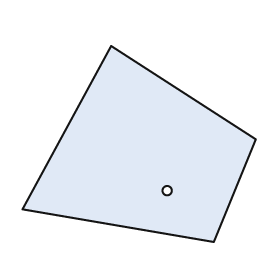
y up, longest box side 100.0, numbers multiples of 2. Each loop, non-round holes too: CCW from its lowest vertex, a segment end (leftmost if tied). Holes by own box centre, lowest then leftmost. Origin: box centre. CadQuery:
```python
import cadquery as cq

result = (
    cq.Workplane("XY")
    .moveTo(32.0, -42.0)
    .lineTo(50.0, 2.0)
    .lineTo(-12.0, 42.0)
    .lineTo(-50.0, -28.0)
    .close()
    .moveTo(12.0, -20.0)
    .circle(2.0)
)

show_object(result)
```